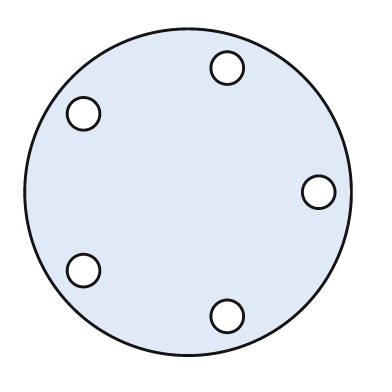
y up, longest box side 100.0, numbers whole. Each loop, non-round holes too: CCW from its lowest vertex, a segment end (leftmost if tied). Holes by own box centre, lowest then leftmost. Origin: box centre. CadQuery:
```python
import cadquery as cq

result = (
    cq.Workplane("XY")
    .moveTo(0.0, 0.0)
    .circle(50.0)
    .moveTo(12.0, -38.0)
    .circle(5.0)
    .moveTo(-32.0, -24.0)
    .circle(5.0)
    .moveTo(40.0, 0.0)
    .circle(5.0)
    .moveTo(-32.0, 24.0)
    .circle(5.0)
    .moveTo(12.0, 38.0)
    .circle(5.0)
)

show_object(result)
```